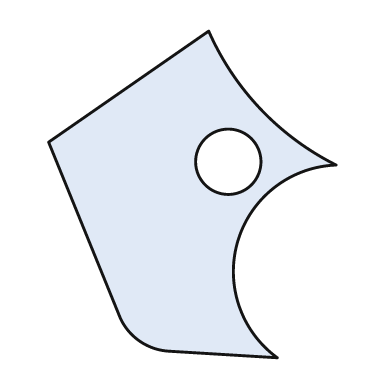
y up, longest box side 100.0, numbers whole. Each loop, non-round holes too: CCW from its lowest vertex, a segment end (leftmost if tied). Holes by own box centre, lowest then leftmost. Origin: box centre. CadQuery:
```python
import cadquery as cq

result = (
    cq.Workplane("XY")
    .moveTo(26.0, -50.0)
    .threePointArc((14.0, -14.0), (44.0, 9.0))
    .threePointArc((21.0, 26.0), (5.0, 50.0))
    .lineTo(-44.0, 16.0)
    .lineTo(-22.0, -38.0)
    .threePointArc((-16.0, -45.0), (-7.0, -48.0))
    .close()
    .moveTo(11.0, 10.0)
    .circle(10.0)
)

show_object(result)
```